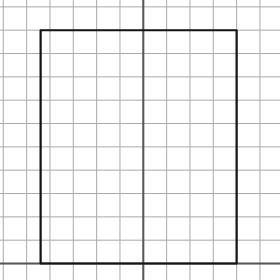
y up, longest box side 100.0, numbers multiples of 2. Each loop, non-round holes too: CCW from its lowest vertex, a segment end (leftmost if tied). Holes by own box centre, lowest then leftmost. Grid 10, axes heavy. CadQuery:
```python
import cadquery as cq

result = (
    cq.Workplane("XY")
    .moveTo(-44.0, 0.0)
    .lineTo(40.0, 0.0)
    .lineTo(40.0, 100.0)
    .lineTo(-44.0, 100.0)
    .close()
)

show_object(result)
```